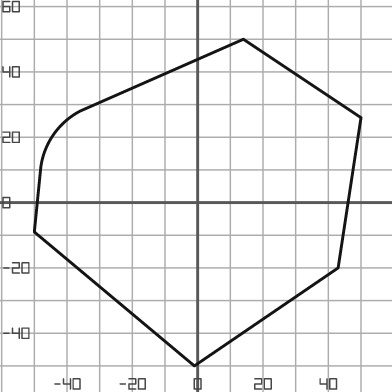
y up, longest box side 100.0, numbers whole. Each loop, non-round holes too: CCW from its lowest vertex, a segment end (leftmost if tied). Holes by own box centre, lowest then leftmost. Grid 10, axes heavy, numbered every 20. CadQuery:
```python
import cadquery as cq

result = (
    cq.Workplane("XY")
    .moveTo(-1.0, -50.0)
    .lineTo(43.0, -20.0)
    .lineTo(50.0, 26.0)
    .lineTo(14.0, 50.0)
    .lineTo(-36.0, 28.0)
    .threePointArc((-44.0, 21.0), (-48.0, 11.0))
    .lineTo(-50.0, -9.0)
    .close()
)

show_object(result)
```